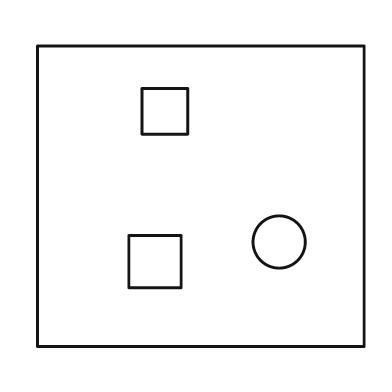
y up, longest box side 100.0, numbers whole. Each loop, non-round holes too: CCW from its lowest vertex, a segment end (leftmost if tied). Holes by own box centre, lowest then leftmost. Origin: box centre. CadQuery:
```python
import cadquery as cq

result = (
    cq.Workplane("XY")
    .moveTo(-50.0, -46.0)
    .lineTo(50.0, -46.0)
    .lineTo(50.0, 46.0)
    .lineTo(-50.0, 46.0)
    .close()
    .moveTo(-22.0, -28.0)
    .lineTo(-6.0, -28.0)
    .lineTo(-6.0, -12.0)
    .lineTo(-22.0, -12.0)
    .close()
    .moveTo(24.0, -14.0)
    .circle(8.0)
    .moveTo(-18.0, 19.0)
    .lineTo(-4.0, 19.0)
    .lineTo(-4.0, 33.0)
    .lineTo(-18.0, 33.0)
    .close()
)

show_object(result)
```